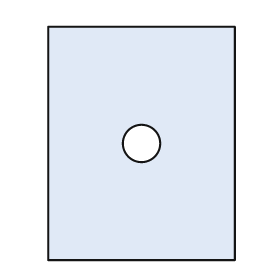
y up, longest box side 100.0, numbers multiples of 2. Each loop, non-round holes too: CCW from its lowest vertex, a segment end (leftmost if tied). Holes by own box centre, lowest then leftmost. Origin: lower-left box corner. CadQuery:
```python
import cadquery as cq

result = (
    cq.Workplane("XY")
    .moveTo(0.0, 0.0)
    .lineTo(80.0, 0.0)
    .lineTo(80.0, 100.0)
    .lineTo(0.0, 100.0)
    .close()
    .moveTo(40.0, 50.0)
    .circle(8.0)
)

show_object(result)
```